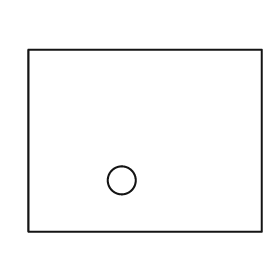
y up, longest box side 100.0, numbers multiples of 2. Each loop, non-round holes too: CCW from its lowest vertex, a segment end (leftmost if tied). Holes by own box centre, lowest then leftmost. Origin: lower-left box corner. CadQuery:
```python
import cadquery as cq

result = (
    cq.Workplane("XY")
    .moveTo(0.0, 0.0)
    .lineTo(100.0, 0.0)
    .lineTo(100.0, 78.0)
    .lineTo(0.0, 78.0)
    .close()
    .moveTo(40.0, 22.0)
    .circle(6.0)
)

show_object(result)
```